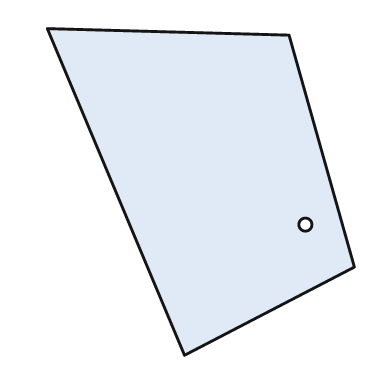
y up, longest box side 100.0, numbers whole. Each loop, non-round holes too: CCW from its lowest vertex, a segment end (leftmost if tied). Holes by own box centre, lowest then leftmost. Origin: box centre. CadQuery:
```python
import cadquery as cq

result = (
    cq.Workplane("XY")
    .moveTo(-5.0, -50.0)
    .lineTo(47.0, -23.0)
    .lineTo(27.0, 48.0)
    .lineTo(-47.0, 50.0)
    .close()
    .moveTo(32.0, -10.0)
    .circle(2.0)
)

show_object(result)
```